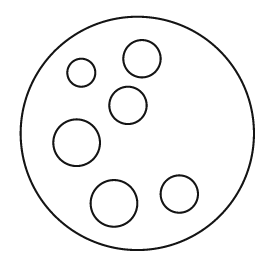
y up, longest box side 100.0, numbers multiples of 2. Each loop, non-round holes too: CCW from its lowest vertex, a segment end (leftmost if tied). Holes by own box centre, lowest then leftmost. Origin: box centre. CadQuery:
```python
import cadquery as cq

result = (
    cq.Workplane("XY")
    .moveTo(0.0, 0.0)
    .circle(50.0)
    .moveTo(-10.0, -30.0)
    .circle(10.0)
    .moveTo(18.0, -26.0)
    .circle(8.0)
    .moveTo(-26.0, -4.0)
    .circle(10.0)
    .moveTo(-4.0, 12.0)
    .circle(8.0)
    .moveTo(-24.0, 26.0)
    .circle(6.0)
    .moveTo(2.0, 32.0)
    .circle(8.0)
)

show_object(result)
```